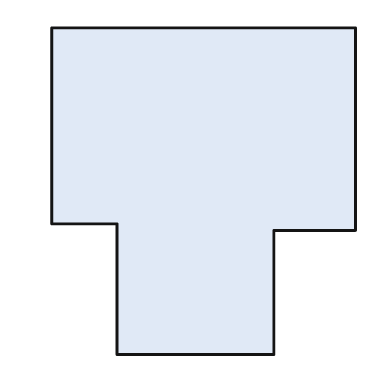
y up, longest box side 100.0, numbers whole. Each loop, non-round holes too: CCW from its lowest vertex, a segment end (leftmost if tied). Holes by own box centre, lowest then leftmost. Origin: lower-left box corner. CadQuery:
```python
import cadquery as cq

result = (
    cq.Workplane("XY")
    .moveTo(20.0, 0.0)
    .lineTo(68.0, 0.0)
    .lineTo(68.0, 38.0)
    .lineTo(93.0, 38.0)
    .lineTo(93.0, 100.0)
    .lineTo(0.0, 100.0)
    .lineTo(0.0, 40.0)
    .lineTo(20.0, 40.0)
    .close()
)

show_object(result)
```